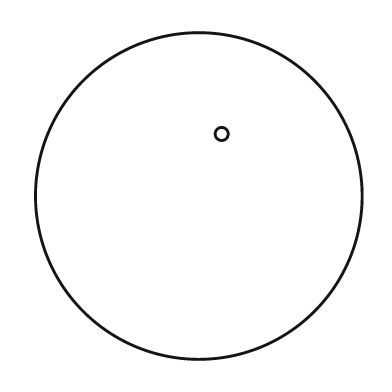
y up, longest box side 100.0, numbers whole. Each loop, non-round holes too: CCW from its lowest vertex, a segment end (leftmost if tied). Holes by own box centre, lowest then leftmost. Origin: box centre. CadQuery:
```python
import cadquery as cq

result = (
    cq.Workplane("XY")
    .moveTo(0.0, 0.0)
    .circle(50.0)
    .moveTo(7.0, 19.0)
    .circle(2.0)
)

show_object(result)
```